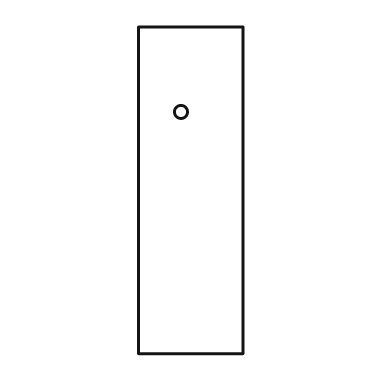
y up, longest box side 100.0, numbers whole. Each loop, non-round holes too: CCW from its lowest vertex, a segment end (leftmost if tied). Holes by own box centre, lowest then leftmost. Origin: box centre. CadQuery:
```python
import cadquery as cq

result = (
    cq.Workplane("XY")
    .moveTo(-16.0, -50.0)
    .lineTo(16.0, -50.0)
    .lineTo(16.0, 50.0)
    .lineTo(-16.0, 50.0)
    .close()
    .moveTo(-3.0, 24.0)
    .circle(2.0)
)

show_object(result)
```